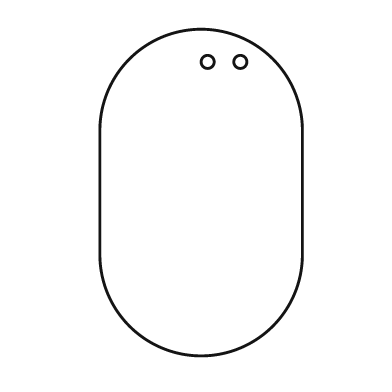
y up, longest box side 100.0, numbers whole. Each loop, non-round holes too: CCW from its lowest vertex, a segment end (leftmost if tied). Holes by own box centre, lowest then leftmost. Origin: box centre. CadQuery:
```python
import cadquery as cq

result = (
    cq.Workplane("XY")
    .moveTo(-31.0, -19.0)
    .threePointArc((0.0, -50.0), (31.0, -19.0))
    .lineTo(31.0, 19.0)
    .threePointArc((0.0, 50.0), (-31.0, 19.0))
    .close()
    .moveTo(2.0, 40.0)
    .circle(2.0)
    .moveTo(12.0, 40.0)
    .circle(2.0)
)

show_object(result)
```